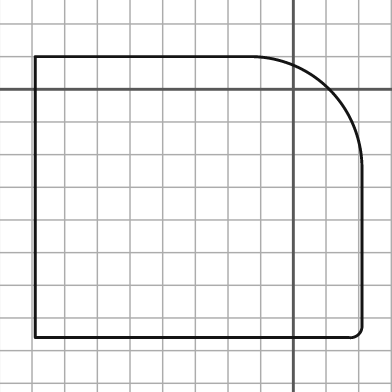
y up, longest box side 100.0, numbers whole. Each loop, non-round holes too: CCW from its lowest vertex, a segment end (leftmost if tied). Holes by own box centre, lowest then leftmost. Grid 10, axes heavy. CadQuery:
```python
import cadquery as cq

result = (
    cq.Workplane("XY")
    .moveTo(-79.0, -76.0)
    .lineTo(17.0, -76.0)
    .threePointArc((20.0, -75.0), (21.0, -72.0))
    .lineTo(21.0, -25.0)
    .threePointArc((11.0, 0.0), (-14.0, 10.0))
    .lineTo(-79.0, 10.0)
    .close()
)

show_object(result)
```